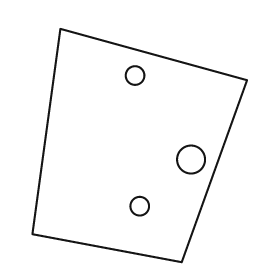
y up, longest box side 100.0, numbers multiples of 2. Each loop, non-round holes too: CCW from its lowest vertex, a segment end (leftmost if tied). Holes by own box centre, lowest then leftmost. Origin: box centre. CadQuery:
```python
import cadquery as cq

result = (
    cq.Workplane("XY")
    .moveTo(18.0, -50.0)
    .lineTo(46.0, 28.0)
    .lineTo(-34.0, 50.0)
    .lineTo(-46.0, -38.0)
    .close()
    .moveTo(0.0, -26.0)
    .circle(4.0)
    .moveTo(22.0, -6.0)
    .circle(6.0)
    .moveTo(-2.0, 30.0)
    .circle(4.0)
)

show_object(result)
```